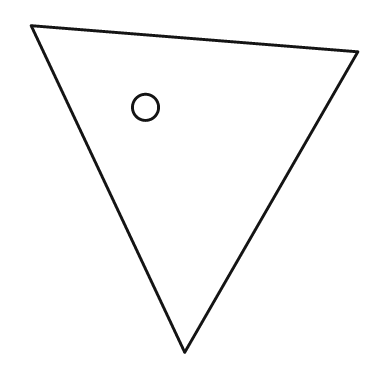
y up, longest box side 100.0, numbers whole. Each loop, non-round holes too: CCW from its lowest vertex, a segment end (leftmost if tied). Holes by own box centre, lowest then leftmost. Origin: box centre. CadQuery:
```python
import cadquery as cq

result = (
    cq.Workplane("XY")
    .moveTo(-3.0, -50.0)
    .lineTo(50.0, 42.0)
    .lineTo(-50.0, 50.0)
    .close()
    .moveTo(-15.0, 25.0)
    .circle(4.0)
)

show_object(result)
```